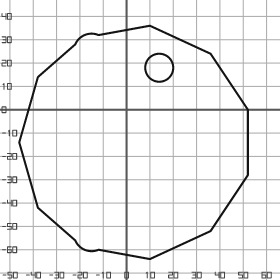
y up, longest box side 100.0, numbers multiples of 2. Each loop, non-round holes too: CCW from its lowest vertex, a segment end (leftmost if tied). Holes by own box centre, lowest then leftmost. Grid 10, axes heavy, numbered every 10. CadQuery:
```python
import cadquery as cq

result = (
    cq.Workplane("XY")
    .moveTo(10.0, -64.0)
    .lineTo(36.0, -52.0)
    .lineTo(52.0, -28.0)
    .lineTo(52.0, 0.0)
    .lineTo(36.0, 24.0)
    .lineTo(10.0, 36.0)
    .lineTo(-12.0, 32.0)
    .threePointArc((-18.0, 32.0), (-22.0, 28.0))
    .lineTo(-38.0, 14.0)
    .lineTo(-46.0, -14.0)
    .lineTo(-38.0, -42.0)
    .lineTo(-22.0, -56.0)
    .threePointArc((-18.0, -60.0), (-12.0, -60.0))
    .close()
    .moveTo(14.0, 18.0)
    .circle(6.0)
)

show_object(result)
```